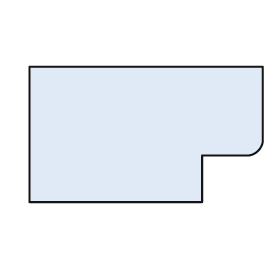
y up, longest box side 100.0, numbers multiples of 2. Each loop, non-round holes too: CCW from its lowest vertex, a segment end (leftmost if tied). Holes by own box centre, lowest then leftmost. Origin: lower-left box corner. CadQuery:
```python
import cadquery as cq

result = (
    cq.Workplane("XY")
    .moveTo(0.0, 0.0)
    .lineTo(74.0, 0.0)
    .lineTo(74.0, 20.0)
    .lineTo(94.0, 20.0)
    .threePointArc((98.0, 22.0), (100.0, 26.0))
    .lineTo(100.0, 58.0)
    .lineTo(0.0, 58.0)
    .close()
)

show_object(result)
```